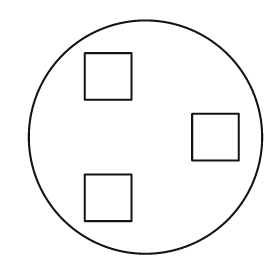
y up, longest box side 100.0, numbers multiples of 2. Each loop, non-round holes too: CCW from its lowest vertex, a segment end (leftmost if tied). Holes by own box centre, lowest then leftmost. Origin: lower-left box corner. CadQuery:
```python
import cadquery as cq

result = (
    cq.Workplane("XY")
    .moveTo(50.0, 50.0)
    .circle(50.0)
    .moveTo(24.0, 14.0)
    .lineTo(44.0, 14.0)
    .lineTo(44.0, 34.0)
    .lineTo(24.0, 34.0)
    .close()
    .moveTo(70.0, 40.0)
    .lineTo(90.0, 40.0)
    .lineTo(90.0, 60.0)
    .lineTo(70.0, 60.0)
    .close()
    .moveTo(24.0, 66.0)
    .lineTo(44.0, 66.0)
    .lineTo(44.0, 86.0)
    .lineTo(24.0, 86.0)
    .close()
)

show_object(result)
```